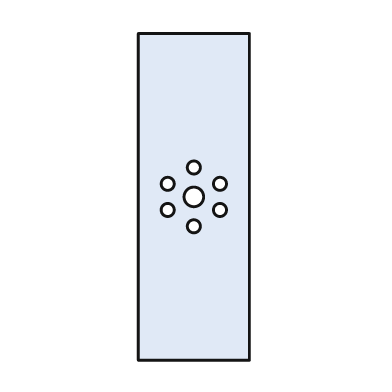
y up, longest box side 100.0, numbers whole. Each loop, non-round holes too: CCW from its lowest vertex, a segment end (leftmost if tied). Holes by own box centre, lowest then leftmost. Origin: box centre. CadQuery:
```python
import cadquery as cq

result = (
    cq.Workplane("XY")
    .moveTo(-17.0, -50.0)
    .lineTo(17.0, -50.0)
    .lineTo(17.0, 50.0)
    .lineTo(-17.0, 50.0)
    .close()
    .moveTo(0.0, -9.0)
    .circle(2.0)
    .moveTo(-8.0, -4.0)
    .circle(2.0)
    .moveTo(8.0, -4.0)
    .circle(2.0)
    .moveTo(0.0, 0.0)
    .circle(3.0)
    .moveTo(-8.0, 4.0)
    .circle(2.0)
    .moveTo(8.0, 4.0)
    .circle(2.0)
    .moveTo(0.0, 9.0)
    .circle(2.0)
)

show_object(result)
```